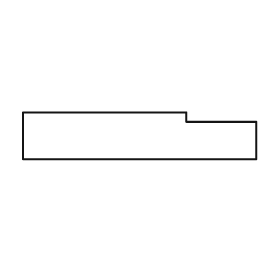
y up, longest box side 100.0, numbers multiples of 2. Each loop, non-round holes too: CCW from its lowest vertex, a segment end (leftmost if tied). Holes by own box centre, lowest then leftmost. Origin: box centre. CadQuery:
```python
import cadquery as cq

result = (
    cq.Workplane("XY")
    .moveTo(-50.0, -10.0)
    .lineTo(50.0, -10.0)
    .lineTo(50.0, 6.0)
    .lineTo(20.0, 6.0)
    .lineTo(20.0, 10.0)
    .lineTo(-50.0, 10.0)
    .close()
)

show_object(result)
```